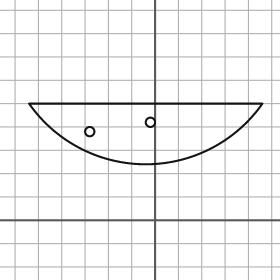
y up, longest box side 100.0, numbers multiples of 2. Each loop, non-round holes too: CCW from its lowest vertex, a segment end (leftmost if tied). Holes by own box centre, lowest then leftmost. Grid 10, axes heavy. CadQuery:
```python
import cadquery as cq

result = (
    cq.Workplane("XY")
    .moveTo(-54.0, 50.0)
    .threePointArc((-4.0, 24.0), (46.0, 50.0))
    .close()
    .moveTo(-28.0, 38.0)
    .circle(2.0)
    .moveTo(-2.0, 42.0)
    .circle(2.0)
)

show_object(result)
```